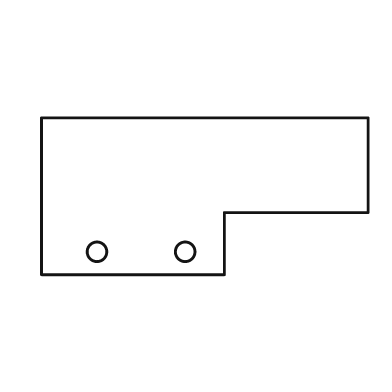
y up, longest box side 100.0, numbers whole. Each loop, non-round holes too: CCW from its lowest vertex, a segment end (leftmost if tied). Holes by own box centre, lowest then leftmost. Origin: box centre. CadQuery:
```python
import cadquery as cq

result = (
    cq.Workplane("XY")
    .moveTo(-50.0, -24.0)
    .lineTo(6.0, -24.0)
    .lineTo(6.0, -5.0)
    .lineTo(50.0, -5.0)
    .lineTo(50.0, 24.0)
    .lineTo(-50.0, 24.0)
    .close()
    .moveTo(-33.0, -17.0)
    .circle(3.0)
    .moveTo(-6.0, -17.0)
    .circle(3.0)
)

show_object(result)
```